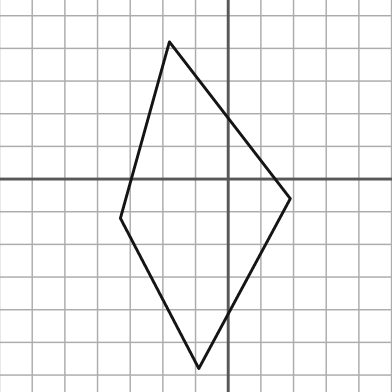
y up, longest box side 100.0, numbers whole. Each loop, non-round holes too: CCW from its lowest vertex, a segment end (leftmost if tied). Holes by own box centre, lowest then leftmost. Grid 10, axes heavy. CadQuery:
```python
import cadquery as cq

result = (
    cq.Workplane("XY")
    .moveTo(-9.0, -58.0)
    .lineTo(19.0, -6.0)
    .lineTo(-18.0, 42.0)
    .lineTo(-33.0, -12.0)
    .close()
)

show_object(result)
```